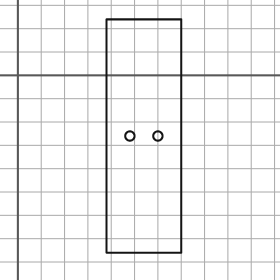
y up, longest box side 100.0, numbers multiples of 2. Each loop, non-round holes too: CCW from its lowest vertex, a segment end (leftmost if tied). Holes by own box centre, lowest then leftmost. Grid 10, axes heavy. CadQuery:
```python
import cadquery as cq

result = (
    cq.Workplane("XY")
    .moveTo(38.0, -76.0)
    .lineTo(70.0, -76.0)
    .lineTo(70.0, 24.0)
    .lineTo(38.0, 24.0)
    .close()
    .moveTo(48.0, -26.0)
    .circle(2.0)
    .moveTo(60.0, -26.0)
    .circle(2.0)
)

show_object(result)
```